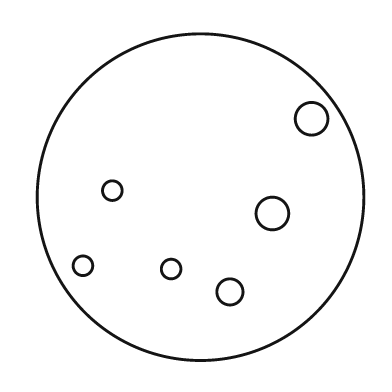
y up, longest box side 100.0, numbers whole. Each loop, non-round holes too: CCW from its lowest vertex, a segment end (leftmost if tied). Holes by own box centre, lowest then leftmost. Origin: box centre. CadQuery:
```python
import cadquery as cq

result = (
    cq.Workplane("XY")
    .moveTo(0.0, 0.0)
    .circle(50.0)
    .moveTo(9.0, -29.0)
    .circle(4.0)
    .moveTo(-9.0, -22.0)
    .circle(3.0)
    .moveTo(-36.0, -21.0)
    .circle(3.0)
    .moveTo(22.0, -5.0)
    .circle(5.0)
    .moveTo(-27.0, 2.0)
    .circle(3.0)
    .moveTo(34.0, 24.0)
    .circle(5.0)
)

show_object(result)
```